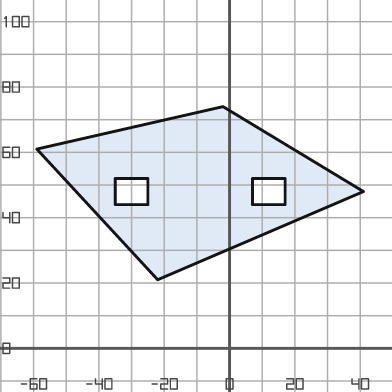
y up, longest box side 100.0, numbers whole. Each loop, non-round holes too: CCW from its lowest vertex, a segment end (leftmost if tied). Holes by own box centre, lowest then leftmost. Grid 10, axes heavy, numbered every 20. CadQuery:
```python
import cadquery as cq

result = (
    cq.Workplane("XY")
    .moveTo(-22.0, 21.0)
    .lineTo(41.0, 48.0)
    .lineTo(-2.0, 74.0)
    .lineTo(-59.0, 61.0)
    .close()
    .moveTo(-35.0, 44.0)
    .lineTo(-25.0, 44.0)
    .lineTo(-25.0, 52.0)
    .lineTo(-35.0, 52.0)
    .close()
    .moveTo(7.0, 44.0)
    .lineTo(17.0, 44.0)
    .lineTo(17.0, 52.0)
    .lineTo(7.0, 52.0)
    .close()
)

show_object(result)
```